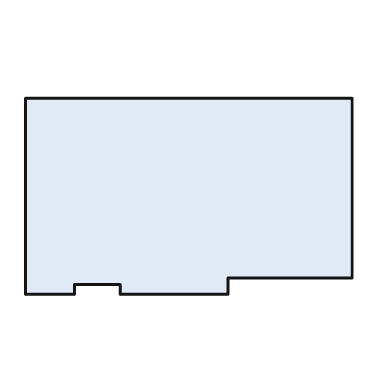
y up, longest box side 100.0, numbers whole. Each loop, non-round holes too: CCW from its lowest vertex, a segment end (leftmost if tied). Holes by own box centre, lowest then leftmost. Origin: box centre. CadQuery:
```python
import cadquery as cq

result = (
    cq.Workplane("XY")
    .moveTo(-50.0, -30.0)
    .lineTo(-35.0, -30.0)
    .lineTo(-35.0, -27.0)
    .lineTo(-21.0, -27.0)
    .lineTo(-21.0, -30.0)
    .lineTo(12.0, -30.0)
    .lineTo(12.0, -25.0)
    .lineTo(50.0, -25.0)
    .lineTo(50.0, 30.0)
    .lineTo(-50.0, 30.0)
    .close()
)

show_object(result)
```